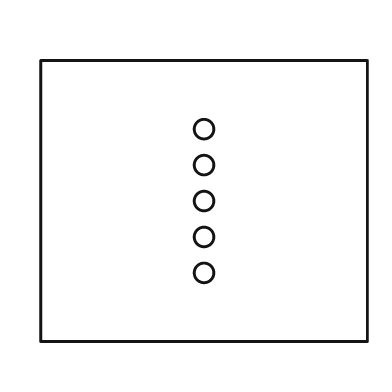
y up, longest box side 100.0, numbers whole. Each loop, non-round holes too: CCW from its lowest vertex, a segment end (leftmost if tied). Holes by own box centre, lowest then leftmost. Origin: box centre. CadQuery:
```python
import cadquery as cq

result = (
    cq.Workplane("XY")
    .moveTo(-50.0, -43.0)
    .lineTo(50.0, -43.0)
    .lineTo(50.0, 43.0)
    .lineTo(-50.0, 43.0)
    .close()
    .moveTo(0.0, -22.0)
    .circle(3.0)
    .moveTo(0.0, -11.0)
    .circle(3.0)
    .moveTo(0.0, 0.0)
    .circle(3.0)
    .moveTo(0.0, 11.0)
    .circle(3.0)
    .moveTo(0.0, 22.0)
    .circle(3.0)
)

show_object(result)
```